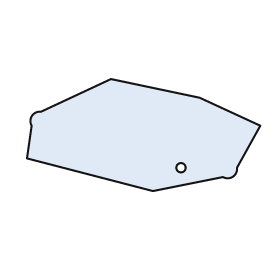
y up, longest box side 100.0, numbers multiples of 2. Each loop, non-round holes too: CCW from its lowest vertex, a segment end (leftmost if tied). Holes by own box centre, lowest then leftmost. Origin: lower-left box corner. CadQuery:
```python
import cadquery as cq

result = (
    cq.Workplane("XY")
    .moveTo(54.0, 0.0)
    .lineTo(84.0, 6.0)
    .threePointArc((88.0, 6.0), (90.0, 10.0))
    .lineTo(100.0, 28.0)
    .lineTo(74.0, 40.0)
    .lineTo(36.0, 48.0)
    .lineTo(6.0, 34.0)
    .threePointArc((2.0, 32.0), (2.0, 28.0))
    .lineTo(0.0, 14.0)
    .close()
    .moveTo(66.0, 10.0)
    .circle(2.0)
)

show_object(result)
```